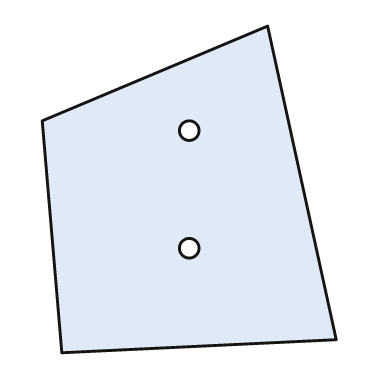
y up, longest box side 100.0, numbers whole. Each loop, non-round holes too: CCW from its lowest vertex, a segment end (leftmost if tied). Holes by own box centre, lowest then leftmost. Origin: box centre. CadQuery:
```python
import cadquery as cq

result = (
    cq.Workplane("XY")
    .moveTo(-39.0, -50.0)
    .lineTo(45.0, -46.0)
    .lineTo(24.0, 50.0)
    .lineTo(-45.0, 21.0)
    .close()
    .moveTo(0.0, -18.0)
    .circle(3.0)
    .moveTo(0.0, 18.0)
    .circle(3.0)
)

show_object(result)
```